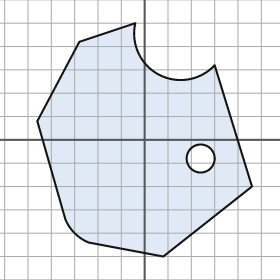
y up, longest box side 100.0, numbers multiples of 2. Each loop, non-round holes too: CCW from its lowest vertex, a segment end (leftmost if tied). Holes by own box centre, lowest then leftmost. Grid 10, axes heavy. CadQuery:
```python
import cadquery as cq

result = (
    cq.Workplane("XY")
    .moveTo(8.0, -50.0)
    .lineTo(46.0, -20.0)
    .lineTo(30.0, 32.0)
    .threePointArc((6.0, 28.0), (-4.0, 50.0))
    .lineTo(-28.0, 42.0)
    .lineTo(-46.0, 8.0)
    .lineTo(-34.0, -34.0)
    .threePointArc((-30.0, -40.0), (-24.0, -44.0))
    .close()
    .moveTo(24.0, -8.0)
    .circle(6.0)
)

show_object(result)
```